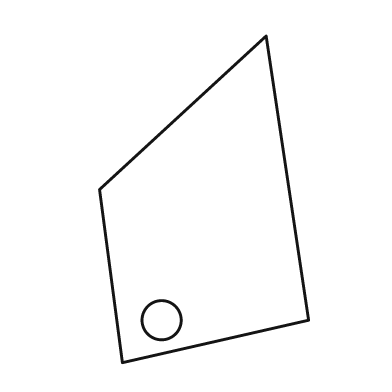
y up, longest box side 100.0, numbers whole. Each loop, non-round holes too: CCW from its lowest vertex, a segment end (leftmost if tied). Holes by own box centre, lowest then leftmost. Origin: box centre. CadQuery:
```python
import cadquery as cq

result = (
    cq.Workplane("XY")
    .moveTo(-25.0, -50.0)
    .lineTo(32.0, -37.0)
    .lineTo(19.0, 50.0)
    .lineTo(-32.0, 3.0)
    .close()
    .moveTo(-13.0, -37.0)
    .circle(6.0)
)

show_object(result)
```